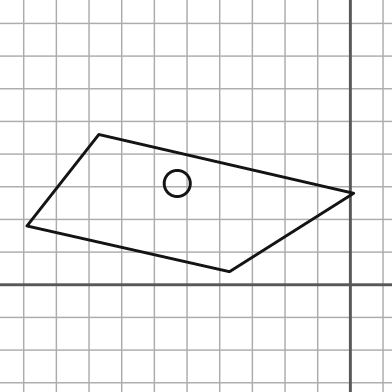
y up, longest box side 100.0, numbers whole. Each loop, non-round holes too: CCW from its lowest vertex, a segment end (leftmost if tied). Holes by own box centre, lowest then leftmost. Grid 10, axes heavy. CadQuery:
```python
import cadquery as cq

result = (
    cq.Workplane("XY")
    .moveTo(-37.0, 4.0)
    .lineTo(1.0, 28.0)
    .lineTo(-77.0, 46.0)
    .lineTo(-99.0, 18.0)
    .close()
    .moveTo(-53.0, 31.0)
    .circle(4.0)
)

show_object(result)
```